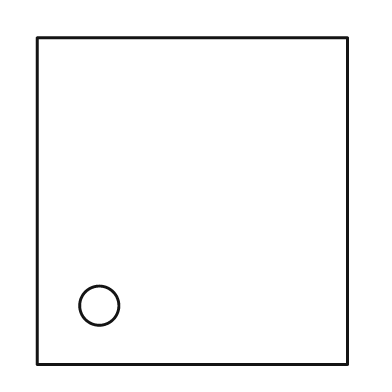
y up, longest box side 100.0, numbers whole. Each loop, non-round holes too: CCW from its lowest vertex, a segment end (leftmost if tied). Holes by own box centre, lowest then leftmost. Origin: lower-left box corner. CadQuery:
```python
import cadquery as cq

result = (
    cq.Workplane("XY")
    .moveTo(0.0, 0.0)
    .lineTo(95.0, 0.0)
    .lineTo(95.0, 100.0)
    .lineTo(0.0, 100.0)
    .close()
    .moveTo(19.0, 18.0)
    .circle(6.0)
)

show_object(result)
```